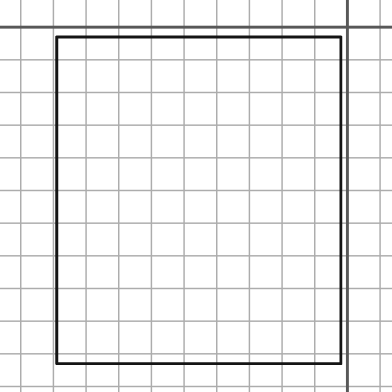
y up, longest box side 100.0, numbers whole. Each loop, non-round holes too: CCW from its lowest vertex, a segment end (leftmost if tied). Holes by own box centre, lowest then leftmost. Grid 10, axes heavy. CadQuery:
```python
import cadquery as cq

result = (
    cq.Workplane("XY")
    .moveTo(-89.0, -103.0)
    .lineTo(-2.0, -103.0)
    .lineTo(-2.0, -3.0)
    .lineTo(-89.0, -3.0)
    .close()
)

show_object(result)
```